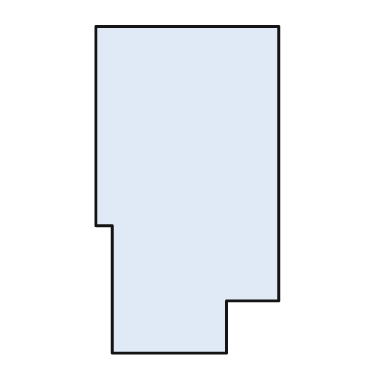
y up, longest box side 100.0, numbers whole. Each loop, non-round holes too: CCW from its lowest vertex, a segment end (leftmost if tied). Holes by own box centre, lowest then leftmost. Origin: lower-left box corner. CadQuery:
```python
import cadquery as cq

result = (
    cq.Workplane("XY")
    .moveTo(5.0, 0.0)
    .lineTo(40.0, 0.0)
    .lineTo(40.0, 16.0)
    .lineTo(56.0, 16.0)
    .lineTo(56.0, 100.0)
    .lineTo(0.0, 100.0)
    .lineTo(0.0, 39.0)
    .lineTo(5.0, 39.0)
    .close()
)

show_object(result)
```